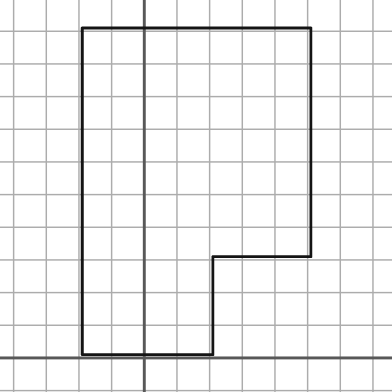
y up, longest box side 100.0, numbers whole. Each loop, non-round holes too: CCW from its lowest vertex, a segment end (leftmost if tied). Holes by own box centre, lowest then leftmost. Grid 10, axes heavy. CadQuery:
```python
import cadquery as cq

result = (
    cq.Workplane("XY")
    .moveTo(-19.0, 1.0)
    .lineTo(21.0, 1.0)
    .lineTo(21.0, 31.0)
    .lineTo(51.0, 31.0)
    .lineTo(51.0, 101.0)
    .lineTo(-19.0, 101.0)
    .close()
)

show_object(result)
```